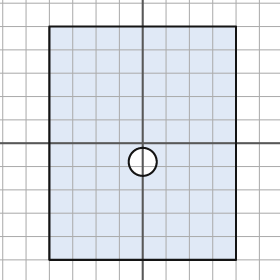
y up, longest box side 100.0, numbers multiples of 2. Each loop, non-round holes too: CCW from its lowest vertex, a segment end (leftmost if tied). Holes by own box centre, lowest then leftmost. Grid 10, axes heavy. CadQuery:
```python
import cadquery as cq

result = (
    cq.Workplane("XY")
    .moveTo(-40.0, -50.0)
    .lineTo(40.0, -50.0)
    .lineTo(40.0, 50.0)
    .lineTo(-40.0, 50.0)
    .close()
    .moveTo(0.0, -8.0)
    .circle(6.0)
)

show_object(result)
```